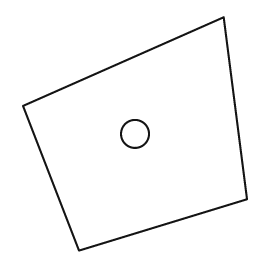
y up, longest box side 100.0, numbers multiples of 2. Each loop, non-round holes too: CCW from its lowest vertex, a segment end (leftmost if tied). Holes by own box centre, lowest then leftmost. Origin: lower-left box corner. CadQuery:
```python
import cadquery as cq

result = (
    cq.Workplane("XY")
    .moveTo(24.0, 0.0)
    .lineTo(96.0, 22.0)
    .lineTo(86.0, 100.0)
    .lineTo(0.0, 62.0)
    .close()
    .moveTo(48.0, 50.0)
    .circle(6.0)
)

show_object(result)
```